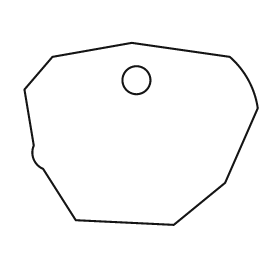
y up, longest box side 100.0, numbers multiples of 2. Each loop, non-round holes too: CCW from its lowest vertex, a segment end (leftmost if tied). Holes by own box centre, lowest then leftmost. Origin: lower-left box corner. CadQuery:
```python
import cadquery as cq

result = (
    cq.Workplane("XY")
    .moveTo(64.0, 0.0)
    .lineTo(86.0, 18.0)
    .lineTo(100.0, 50.0)
    .threePointArc((96.0, 62.0), (88.0, 72.0))
    .lineTo(46.0, 78.0)
    .lineTo(12.0, 72.0)
    .lineTo(0.0, 58.0)
    .lineTo(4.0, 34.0)
    .threePointArc((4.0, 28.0), (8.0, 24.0))
    .lineTo(22.0, 2.0)
    .close()
    .moveTo(48.0, 62.0)
    .circle(6.0)
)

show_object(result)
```